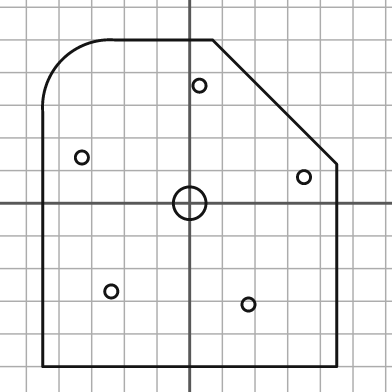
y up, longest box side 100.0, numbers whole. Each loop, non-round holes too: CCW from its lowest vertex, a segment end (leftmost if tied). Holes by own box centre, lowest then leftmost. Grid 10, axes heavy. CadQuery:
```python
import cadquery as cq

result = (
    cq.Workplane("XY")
    .moveTo(-45.0, -50.0)
    .lineTo(45.0, -50.0)
    .lineTo(45.0, 12.0)
    .lineTo(7.0, 50.0)
    .lineTo(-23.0, 50.0)
    .threePointArc((-39.0, 44.0), (-45.0, 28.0))
    .close()
    .moveTo(18.0, -31.0)
    .circle(2.0)
    .moveTo(-24.0, -27.0)
    .circle(2.0)
    .moveTo(0.0, 0.0)
    .circle(5.0)
    .moveTo(35.0, 8.0)
    .circle(2.0)
    .moveTo(-33.0, 14.0)
    .circle(2.0)
    .moveTo(3.0, 36.0)
    .circle(2.0)
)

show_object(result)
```